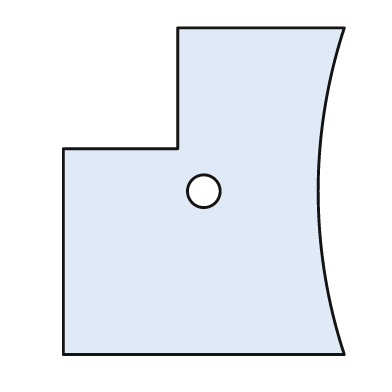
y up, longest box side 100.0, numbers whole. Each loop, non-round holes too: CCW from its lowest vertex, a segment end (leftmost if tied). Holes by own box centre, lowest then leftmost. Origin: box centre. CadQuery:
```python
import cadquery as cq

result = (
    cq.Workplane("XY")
    .moveTo(-43.0, -50.0)
    .lineTo(43.0, -50.0)
    .threePointArc((35.0, 0.0), (43.0, 50.0))
    .lineTo(-8.0, 50.0)
    .lineTo(-8.0, 13.0)
    .lineTo(-43.0, 13.0)
    .close()
    .moveTo(0.0, 0.0)
    .circle(5.0)
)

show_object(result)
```